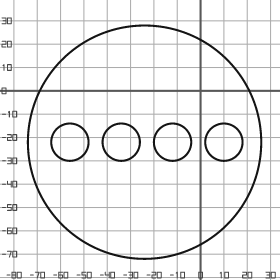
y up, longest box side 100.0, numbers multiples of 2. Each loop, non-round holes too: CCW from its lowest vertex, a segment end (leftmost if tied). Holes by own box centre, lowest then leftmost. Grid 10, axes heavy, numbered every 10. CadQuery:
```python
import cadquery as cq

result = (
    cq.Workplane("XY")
    .moveTo(-24.0, -22.0)
    .circle(50.0)
    .moveTo(-56.0, -22.0)
    .circle(8.0)
    .moveTo(-34.0, -22.0)
    .circle(8.0)
    .moveTo(-12.0, -22.0)
    .circle(8.0)
    .moveTo(10.0, -22.0)
    .circle(8.0)
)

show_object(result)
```